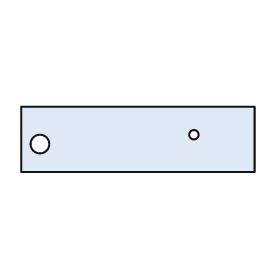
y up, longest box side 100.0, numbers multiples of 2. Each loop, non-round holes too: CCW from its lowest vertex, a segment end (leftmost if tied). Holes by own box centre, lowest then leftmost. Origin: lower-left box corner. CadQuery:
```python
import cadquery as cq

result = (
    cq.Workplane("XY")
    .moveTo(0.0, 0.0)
    .lineTo(100.0, 0.0)
    .lineTo(100.0, 28.0)
    .lineTo(0.0, 28.0)
    .close()
    .moveTo(8.0, 12.0)
    .circle(4.0)
    .moveTo(74.0, 16.0)
    .circle(2.0)
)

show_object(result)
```